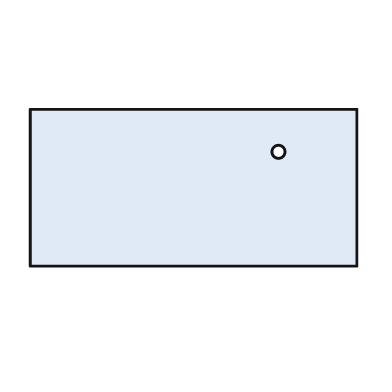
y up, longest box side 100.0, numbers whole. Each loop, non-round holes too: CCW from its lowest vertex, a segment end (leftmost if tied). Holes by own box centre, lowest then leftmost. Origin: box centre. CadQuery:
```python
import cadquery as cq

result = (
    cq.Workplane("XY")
    .moveTo(-50.0, -24.0)
    .lineTo(50.0, -24.0)
    .lineTo(50.0, 24.0)
    .lineTo(-50.0, 24.0)
    .close()
    .moveTo(26.0, 11.0)
    .circle(2.0)
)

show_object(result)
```